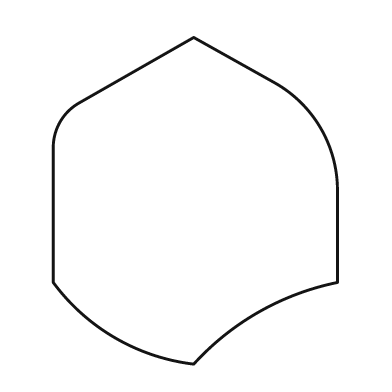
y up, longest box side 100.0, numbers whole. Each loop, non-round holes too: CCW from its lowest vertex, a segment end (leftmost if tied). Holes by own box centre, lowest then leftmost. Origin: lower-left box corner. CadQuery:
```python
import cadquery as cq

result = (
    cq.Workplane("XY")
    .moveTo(43.0, 0.0)
    .threePointArc((63.0, 16.0), (87.0, 25.0))
    .lineTo(87.0, 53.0)
    .threePointArc((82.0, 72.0), (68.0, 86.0))
    .lineTo(43.0, 100.0)
    .lineTo(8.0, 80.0)
    .threePointArc((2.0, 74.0), (0.0, 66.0))
    .lineTo(0.0, 25.0)
    .threePointArc((19.0, 8.0), (43.0, 0.0))
    .close()
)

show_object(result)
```